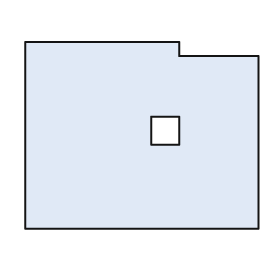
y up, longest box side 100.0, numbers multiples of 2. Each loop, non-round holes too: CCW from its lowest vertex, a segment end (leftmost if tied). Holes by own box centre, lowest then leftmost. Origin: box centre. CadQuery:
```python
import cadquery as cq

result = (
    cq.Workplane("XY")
    .moveTo(-50.0, -40.0)
    .lineTo(50.0, -40.0)
    .lineTo(50.0, 34.0)
    .lineTo(16.0, 34.0)
    .lineTo(16.0, 40.0)
    .lineTo(-50.0, 40.0)
    .close()
    .moveTo(4.0, -4.0)
    .lineTo(16.0, -4.0)
    .lineTo(16.0, 8.0)
    .lineTo(4.0, 8.0)
    .close()
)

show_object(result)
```